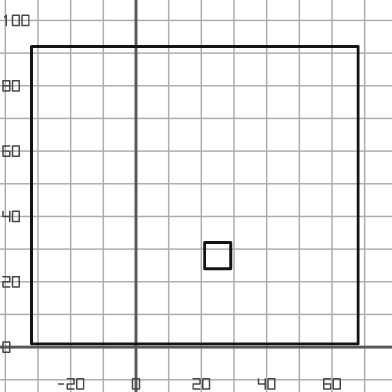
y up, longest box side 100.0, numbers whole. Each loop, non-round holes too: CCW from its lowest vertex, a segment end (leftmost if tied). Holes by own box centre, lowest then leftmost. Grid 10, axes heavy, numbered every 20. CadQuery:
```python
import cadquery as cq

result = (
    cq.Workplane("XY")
    .moveTo(-32.0, 1.0)
    .lineTo(68.0, 1.0)
    .lineTo(68.0, 92.0)
    .lineTo(-32.0, 92.0)
    .close()
    .moveTo(21.0, 24.0)
    .lineTo(29.0, 24.0)
    .lineTo(29.0, 32.0)
    .lineTo(21.0, 32.0)
    .close()
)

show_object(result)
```